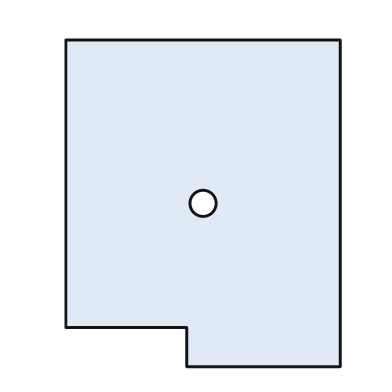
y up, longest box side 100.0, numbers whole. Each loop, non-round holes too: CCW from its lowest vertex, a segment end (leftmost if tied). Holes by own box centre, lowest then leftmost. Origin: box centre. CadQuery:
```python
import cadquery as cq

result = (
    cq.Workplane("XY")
    .moveTo(-5.0, -50.0)
    .lineTo(42.0, -50.0)
    .lineTo(42.0, 50.0)
    .lineTo(-42.0, 50.0)
    .lineTo(-42.0, -38.0)
    .lineTo(-5.0, -38.0)
    .close()
    .moveTo(0.0, 0.0)
    .circle(4.0)
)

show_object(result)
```